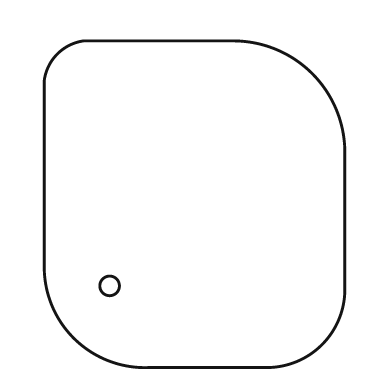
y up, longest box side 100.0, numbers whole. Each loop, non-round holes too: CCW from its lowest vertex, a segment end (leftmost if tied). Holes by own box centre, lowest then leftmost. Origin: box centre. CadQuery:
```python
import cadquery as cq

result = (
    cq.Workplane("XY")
    .moveTo(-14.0, -50.0)
    .lineTo(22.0, -50.0)
    .threePointArc((39.0, -43.0), (46.0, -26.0))
    .lineTo(46.0, 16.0)
    .threePointArc((36.0, 40.0), (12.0, 50.0))
    .lineTo(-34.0, 50.0)
    .threePointArc((-42.0, 46.0), (-46.0, 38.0))
    .lineTo(-46.0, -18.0)
    .threePointArc((-37.0, -41.0), (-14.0, -50.0))
    .close()
    .moveTo(-26.0, -25.0)
    .circle(3.0)
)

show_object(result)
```